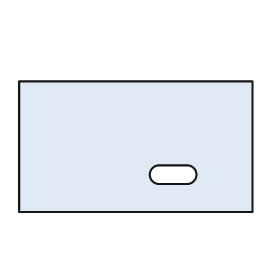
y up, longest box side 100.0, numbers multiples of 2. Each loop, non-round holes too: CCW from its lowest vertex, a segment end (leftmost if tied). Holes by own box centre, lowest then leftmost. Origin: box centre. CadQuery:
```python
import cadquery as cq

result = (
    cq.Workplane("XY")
    .moveTo(-50.0, -28.0)
    .lineTo(50.0, -28.0)
    .lineTo(50.0, 28.0)
    .lineTo(-50.0, 28.0)
    .close()
    .moveTo(10.0, -16.0)
    .lineTo(22.0, -16.0)
    .threePointArc((26.0, -12.0), (22.0, -8.0))
    .lineTo(10.0, -8.0)
    .threePointArc((6.0, -12.0), (10.0, -16.0))
    .close()
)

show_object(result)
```